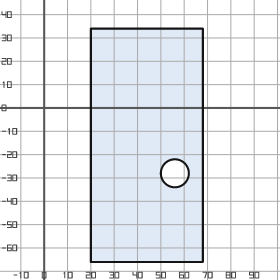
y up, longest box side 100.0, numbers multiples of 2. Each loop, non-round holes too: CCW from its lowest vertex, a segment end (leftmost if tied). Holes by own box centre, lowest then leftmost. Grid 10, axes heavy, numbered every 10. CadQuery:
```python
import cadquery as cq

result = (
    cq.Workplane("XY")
    .moveTo(20.0, -66.0)
    .lineTo(68.0, -66.0)
    .lineTo(68.0, 34.0)
    .lineTo(20.0, 34.0)
    .close()
    .moveTo(56.0, -28.0)
    .circle(6.0)
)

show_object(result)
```